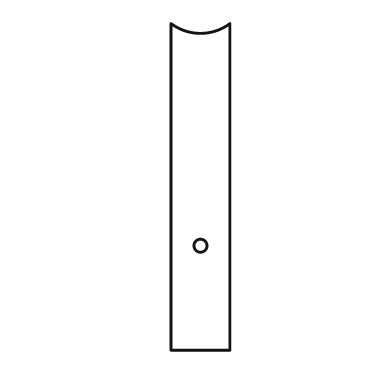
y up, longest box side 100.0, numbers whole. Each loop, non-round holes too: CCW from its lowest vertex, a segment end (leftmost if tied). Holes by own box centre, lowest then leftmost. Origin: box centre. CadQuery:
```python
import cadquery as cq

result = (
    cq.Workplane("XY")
    .moveTo(-9.0, -50.0)
    .lineTo(9.0, -50.0)
    .lineTo(9.0, 50.0)
    .threePointArc((0.0, 47.0), (-9.0, 50.0))
    .close()
    .moveTo(0.0, -18.0)
    .circle(2.0)
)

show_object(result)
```